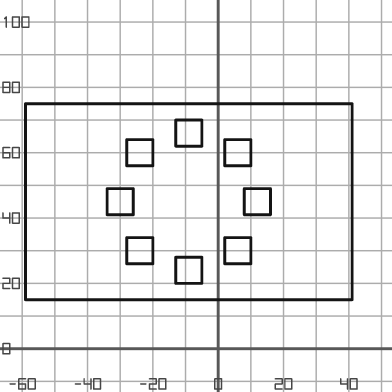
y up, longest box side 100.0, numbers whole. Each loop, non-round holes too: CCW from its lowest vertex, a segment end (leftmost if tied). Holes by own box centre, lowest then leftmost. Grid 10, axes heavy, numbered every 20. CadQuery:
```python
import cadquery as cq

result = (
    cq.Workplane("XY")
    .moveTo(-59.0, 15.0)
    .lineTo(41.0, 15.0)
    .lineTo(41.0, 75.0)
    .lineTo(-59.0, 75.0)
    .close()
    .moveTo(-13.0, 20.0)
    .lineTo(-5.0, 20.0)
    .lineTo(-5.0, 28.0)
    .lineTo(-13.0, 28.0)
    .close()
    .moveTo(-28.0, 26.0)
    .lineTo(-20.0, 26.0)
    .lineTo(-20.0, 34.0)
    .lineTo(-28.0, 34.0)
    .close()
    .moveTo(2.0, 26.0)
    .lineTo(10.0, 26.0)
    .lineTo(10.0, 34.0)
    .lineTo(2.0, 34.0)
    .close()
    .moveTo(-34.0, 41.0)
    .lineTo(-26.0, 41.0)
    .lineTo(-26.0, 49.0)
    .lineTo(-34.0, 49.0)
    .close()
    .moveTo(8.0, 41.0)
    .lineTo(16.0, 41.0)
    .lineTo(16.0, 49.0)
    .lineTo(8.0, 49.0)
    .close()
    .moveTo(-28.0, 56.0)
    .lineTo(-20.0, 56.0)
    .lineTo(-20.0, 64.0)
    .lineTo(-28.0, 64.0)
    .close()
    .moveTo(2.0, 56.0)
    .lineTo(10.0, 56.0)
    .lineTo(10.0, 64.0)
    .lineTo(2.0, 64.0)
    .close()
    .moveTo(-13.0, 62.0)
    .lineTo(-5.0, 62.0)
    .lineTo(-5.0, 70.0)
    .lineTo(-13.0, 70.0)
    .close()
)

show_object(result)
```